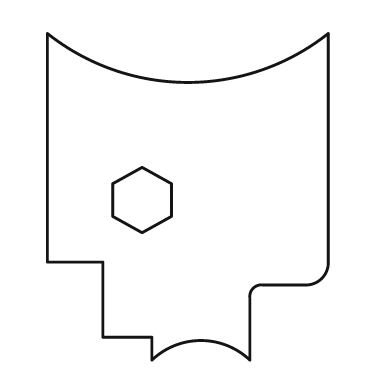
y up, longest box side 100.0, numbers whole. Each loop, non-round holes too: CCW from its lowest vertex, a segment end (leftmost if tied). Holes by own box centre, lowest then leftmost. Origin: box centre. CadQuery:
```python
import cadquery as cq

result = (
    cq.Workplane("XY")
    .moveTo(-11.0, -50.0)
    .threePointArc((4.0, -44.0), (19.0, -50.0))
    .lineTo(19.0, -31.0)
    .threePointArc((20.0, -28.0), (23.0, -27.0))
    .lineTo(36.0, -27.0)
    .threePointArc((41.0, -25.0), (43.0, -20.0))
    .lineTo(43.0, 50.0)
    .threePointArc((0.0, 35.0), (-43.0, 50.0))
    .lineTo(-43.0, -20.0)
    .lineTo(-26.0, -20.0)
    .lineTo(-26.0, -43.0)
    .lineTo(-11.0, -43.0)
    .close()
    .moveTo(-14.0, -11.0)
    .lineTo(-5.0, -6.0)
    .lineTo(-5.0, 4.0)
    .lineTo(-14.0, 9.0)
    .lineTo(-23.0, 4.0)
    .lineTo(-23.0, -6.0)
    .close()
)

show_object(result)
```